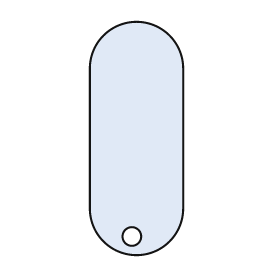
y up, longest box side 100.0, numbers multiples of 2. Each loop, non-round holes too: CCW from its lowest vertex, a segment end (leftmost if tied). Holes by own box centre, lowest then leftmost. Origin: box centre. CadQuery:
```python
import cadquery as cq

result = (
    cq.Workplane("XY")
    .moveTo(-20.0, -30.0)
    .threePointArc((0.0, -50.0), (20.0, -30.0))
    .lineTo(20.0, 30.0)
    .threePointArc((0.0, 50.0), (-20.0, 30.0))
    .close()
    .moveTo(-2.0, -42.0)
    .circle(4.0)
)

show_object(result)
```